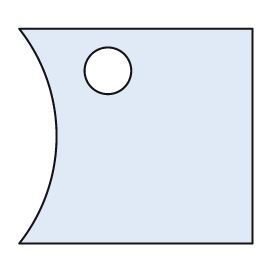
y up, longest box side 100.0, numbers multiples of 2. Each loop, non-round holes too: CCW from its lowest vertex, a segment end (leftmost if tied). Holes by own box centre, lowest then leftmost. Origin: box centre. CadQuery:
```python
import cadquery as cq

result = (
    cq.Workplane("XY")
    .moveTo(-50.0, -46.0)
    .lineTo(50.0, -46.0)
    .lineTo(50.0, 46.0)
    .lineTo(-50.0, 46.0)
    .threePointArc((-34.0, 0.0), (-50.0, -46.0))
    .close()
    .moveTo(-12.0, 28.0)
    .circle(10.0)
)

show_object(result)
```